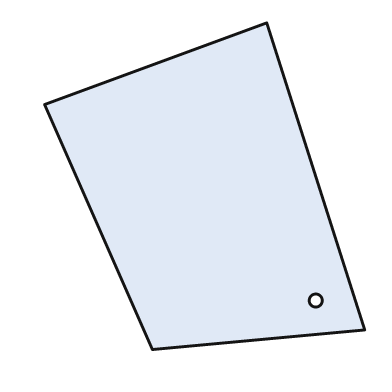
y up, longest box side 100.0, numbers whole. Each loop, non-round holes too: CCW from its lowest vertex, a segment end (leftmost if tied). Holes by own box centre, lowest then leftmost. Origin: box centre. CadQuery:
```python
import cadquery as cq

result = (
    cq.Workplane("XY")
    .moveTo(-16.0, -50.0)
    .lineTo(49.0, -44.0)
    .lineTo(19.0, 50.0)
    .lineTo(-49.0, 25.0)
    .close()
    .moveTo(34.0, -35.0)
    .circle(2.0)
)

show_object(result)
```